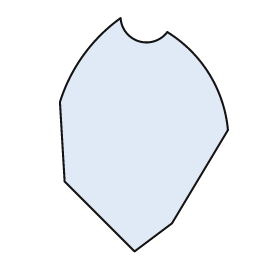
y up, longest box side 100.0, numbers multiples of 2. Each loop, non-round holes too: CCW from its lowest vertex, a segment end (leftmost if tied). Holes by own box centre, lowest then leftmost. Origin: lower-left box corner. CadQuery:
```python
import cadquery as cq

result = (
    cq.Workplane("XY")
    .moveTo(32.0, 0.0)
    .lineTo(48.0, 12.0)
    .lineTo(72.0, 52.0)
    .threePointArc((64.0, 76.0), (46.0, 94.0))
    .threePointArc((34.0, 90.0), (26.0, 100.0))
    .threePointArc((10.0, 84.0), (0.0, 64.0))
    .lineTo(2.0, 30.0)
    .close()
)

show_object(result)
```